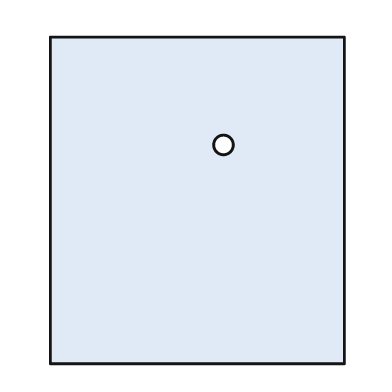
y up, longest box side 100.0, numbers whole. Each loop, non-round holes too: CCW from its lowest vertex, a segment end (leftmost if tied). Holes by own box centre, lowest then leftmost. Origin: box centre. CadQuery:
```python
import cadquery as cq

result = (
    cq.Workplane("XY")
    .moveTo(-45.0, -50.0)
    .lineTo(45.0, -50.0)
    .lineTo(45.0, 50.0)
    .lineTo(-45.0, 50.0)
    .close()
    .moveTo(8.0, 17.0)
    .circle(3.0)
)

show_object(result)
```